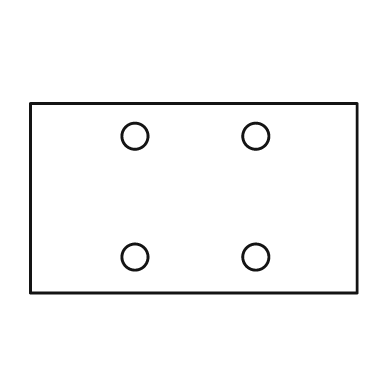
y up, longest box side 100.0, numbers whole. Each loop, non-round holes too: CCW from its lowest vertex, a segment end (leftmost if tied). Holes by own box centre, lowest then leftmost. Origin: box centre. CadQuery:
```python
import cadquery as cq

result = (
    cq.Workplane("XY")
    .moveTo(-50.0, -29.0)
    .lineTo(50.0, -29.0)
    .lineTo(50.0, 29.0)
    .lineTo(-50.0, 29.0)
    .close()
    .moveTo(-18.0, -18.0)
    .circle(4.0)
    .moveTo(19.0, -18.0)
    .circle(4.0)
    .moveTo(-18.0, 19.0)
    .circle(4.0)
    .moveTo(19.0, 19.0)
    .circle(4.0)
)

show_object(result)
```